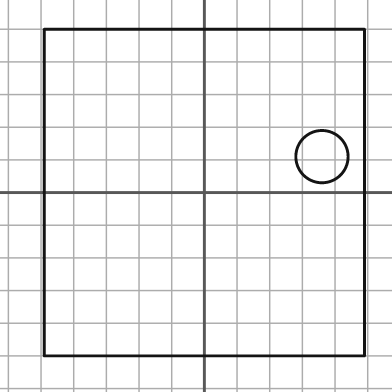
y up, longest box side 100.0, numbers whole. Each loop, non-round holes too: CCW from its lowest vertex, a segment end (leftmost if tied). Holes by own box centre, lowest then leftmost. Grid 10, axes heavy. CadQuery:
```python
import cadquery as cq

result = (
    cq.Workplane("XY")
    .moveTo(-49.0, -50.0)
    .lineTo(49.0, -50.0)
    .lineTo(49.0, 50.0)
    .lineTo(-49.0, 50.0)
    .close()
    .moveTo(36.0, 11.0)
    .circle(8.0)
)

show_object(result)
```